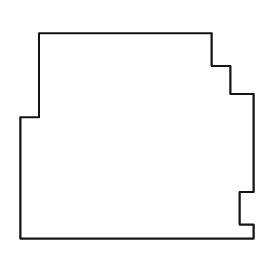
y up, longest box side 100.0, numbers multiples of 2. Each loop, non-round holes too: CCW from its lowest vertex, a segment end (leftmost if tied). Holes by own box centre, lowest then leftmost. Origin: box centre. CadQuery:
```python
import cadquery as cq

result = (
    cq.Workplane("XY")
    .moveTo(-50.0, -44.0)
    .lineTo(50.0, -44.0)
    .lineTo(50.0, -38.0)
    .lineTo(44.0, -38.0)
    .lineTo(44.0, -24.0)
    .lineTo(50.0, -24.0)
    .lineTo(50.0, 18.0)
    .lineTo(40.0, 18.0)
    .lineTo(40.0, 30.0)
    .lineTo(32.0, 30.0)
    .lineTo(32.0, 44.0)
    .lineTo(-42.0, 44.0)
    .lineTo(-42.0, 8.0)
    .lineTo(-50.0, 8.0)
    .close()
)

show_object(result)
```